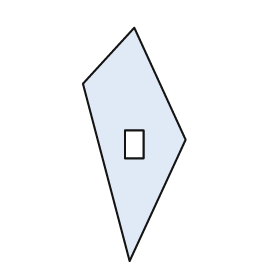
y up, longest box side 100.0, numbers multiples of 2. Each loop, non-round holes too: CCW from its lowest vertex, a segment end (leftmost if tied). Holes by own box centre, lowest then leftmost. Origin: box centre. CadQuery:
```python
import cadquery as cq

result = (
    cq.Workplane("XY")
    .moveTo(-2.0, -50.0)
    .lineTo(22.0, 2.0)
    .lineTo(0.0, 50.0)
    .lineTo(-22.0, 26.0)
    .close()
    .moveTo(-4.0, -6.0)
    .lineTo(4.0, -6.0)
    .lineTo(4.0, 6.0)
    .lineTo(-4.0, 6.0)
    .close()
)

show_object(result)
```